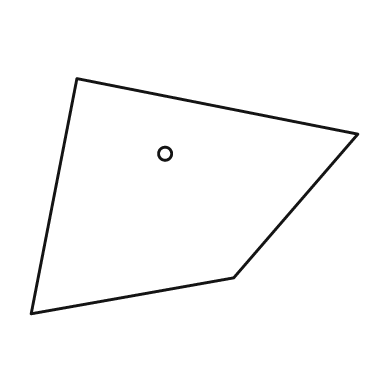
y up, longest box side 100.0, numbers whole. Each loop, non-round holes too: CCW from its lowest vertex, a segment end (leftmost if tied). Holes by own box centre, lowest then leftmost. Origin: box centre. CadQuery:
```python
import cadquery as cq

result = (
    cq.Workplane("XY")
    .moveTo(-50.0, -36.0)
    .lineTo(12.0, -25.0)
    .lineTo(50.0, 19.0)
    .lineTo(-36.0, 36.0)
    .close()
    .moveTo(-9.0, 13.0)
    .circle(2.0)
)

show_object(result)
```